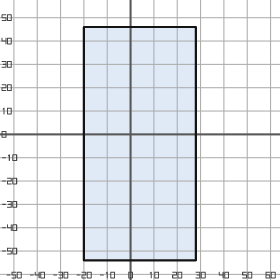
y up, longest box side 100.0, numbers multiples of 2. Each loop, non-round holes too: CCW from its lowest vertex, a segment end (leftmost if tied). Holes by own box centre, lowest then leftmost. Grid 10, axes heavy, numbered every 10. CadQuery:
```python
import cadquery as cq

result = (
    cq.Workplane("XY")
    .moveTo(-20.0, -54.0)
    .lineTo(28.0, -54.0)
    .lineTo(28.0, 46.0)
    .lineTo(-20.0, 46.0)
    .close()
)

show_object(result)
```